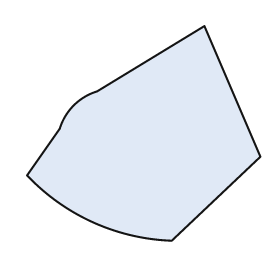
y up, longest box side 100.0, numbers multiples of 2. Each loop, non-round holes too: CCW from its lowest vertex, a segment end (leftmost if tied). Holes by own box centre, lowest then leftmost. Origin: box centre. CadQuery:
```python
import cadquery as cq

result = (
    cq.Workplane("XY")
    .moveTo(12.0, -46.0)
    .lineTo(50.0, -10.0)
    .lineTo(26.0, 46.0)
    .lineTo(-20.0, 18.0)
    .threePointArc((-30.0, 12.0), (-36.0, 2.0))
    .lineTo(-50.0, -18.0)
    .threePointArc((-22.0, -38.0), (12.0, -46.0))
    .close()
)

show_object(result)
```